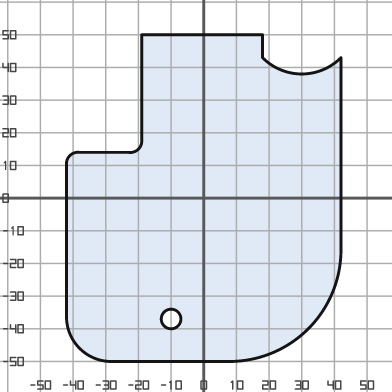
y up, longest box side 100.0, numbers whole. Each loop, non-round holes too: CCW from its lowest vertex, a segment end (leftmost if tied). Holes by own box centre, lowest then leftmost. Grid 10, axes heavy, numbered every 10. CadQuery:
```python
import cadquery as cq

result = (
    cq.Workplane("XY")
    .moveTo(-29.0, -50.0)
    .lineTo(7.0, -50.0)
    .threePointArc((32.0, -40.0), (42.0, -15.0))
    .lineTo(42.0, 43.0)
    .threePointArc((30.0, 38.0), (18.0, 43.0))
    .lineTo(18.0, 50.0)
    .lineTo(-19.0, 50.0)
    .lineTo(-19.0, 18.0)
    .threePointArc((-20.0, 15.0), (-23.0, 14.0))
    .lineTo(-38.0, 14.0)
    .threePointArc((-41.0, 13.0), (-42.0, 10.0))
    .lineTo(-42.0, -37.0)
    .threePointArc((-38.0, -46.0), (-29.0, -50.0))
    .close()
    .moveTo(-10.0, -37.0)
    .circle(3.0)
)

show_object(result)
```